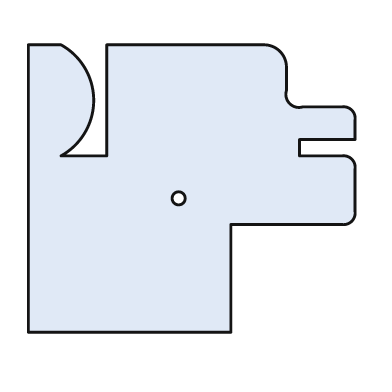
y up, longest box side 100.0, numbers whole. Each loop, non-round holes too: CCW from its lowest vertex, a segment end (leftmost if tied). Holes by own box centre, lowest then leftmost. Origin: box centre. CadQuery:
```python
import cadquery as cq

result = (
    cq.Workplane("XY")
    .moveTo(-50.0, -44.0)
    .lineTo(12.0, -44.0)
    .lineTo(12.0, -11.0)
    .lineTo(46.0, -11.0)
    .threePointArc((49.0, -10.0), (50.0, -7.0))
    .lineTo(50.0, 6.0)
    .threePointArc((49.0, 9.0), (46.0, 10.0))
    .lineTo(33.0, 10.0)
    .lineTo(33.0, 15.0)
    .lineTo(50.0, 15.0)
    .lineTo(50.0, 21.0)
    .threePointArc((49.0, 24.0), (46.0, 25.0))
    .lineTo(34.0, 25.0)
    .threePointArc((30.0, 26.0), (29.0, 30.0))
    .lineTo(29.0, 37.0)
    .threePointArc((27.0, 42.0), (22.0, 44.0))
    .lineTo(-26.0, 44.0)
    .lineTo(-26.0, 10.0)
    .lineTo(-40.0, 10.0)
    .threePointArc((-30.0, 27.0), (-40.0, 44.0))
    .lineTo(-50.0, 44.0)
    .close()
    .moveTo(-4.0, -3.0)
    .circle(2.0)
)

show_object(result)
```